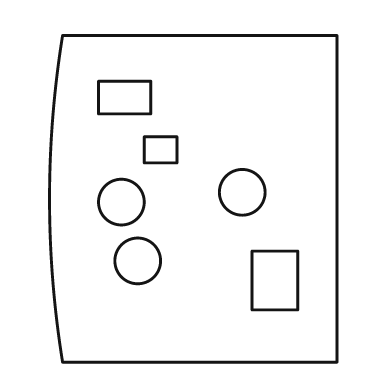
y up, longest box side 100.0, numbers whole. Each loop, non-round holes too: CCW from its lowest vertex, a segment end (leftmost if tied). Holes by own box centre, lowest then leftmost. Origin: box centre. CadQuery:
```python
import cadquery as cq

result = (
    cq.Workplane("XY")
    .moveTo(-40.0, -50.0)
    .lineTo(44.0, -50.0)
    .lineTo(44.0, 50.0)
    .lineTo(-40.0, 50.0)
    .threePointArc((-44.0, 0.0), (-40.0, -50.0))
    .close()
    .moveTo(18.0, -34.0)
    .lineTo(32.0, -34.0)
    .lineTo(32.0, -16.0)
    .lineTo(18.0, -16.0)
    .close()
    .moveTo(-17.0, -19.0)
    .circle(7.0)
    .moveTo(-22.0, -1.0)
    .circle(7.0)
    .moveTo(15.0, 2.0)
    .circle(7.0)
    .moveTo(-15.0, 11.0)
    .lineTo(-5.0, 11.0)
    .lineTo(-5.0, 19.0)
    .lineTo(-15.0, 19.0)
    .close()
    .moveTo(-29.0, 26.0)
    .lineTo(-13.0, 26.0)
    .lineTo(-13.0, 36.0)
    .lineTo(-29.0, 36.0)
    .close()
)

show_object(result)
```